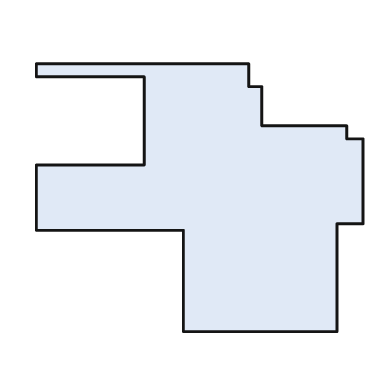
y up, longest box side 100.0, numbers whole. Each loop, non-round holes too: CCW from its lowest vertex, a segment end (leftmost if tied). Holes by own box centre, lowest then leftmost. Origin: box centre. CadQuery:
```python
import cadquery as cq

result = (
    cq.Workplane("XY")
    .moveTo(-5.0, -41.0)
    .lineTo(42.0, -41.0)
    .lineTo(42.0, -8.0)
    .lineTo(50.0, -8.0)
    .lineTo(50.0, 18.0)
    .lineTo(45.0, 18.0)
    .lineTo(45.0, 22.0)
    .lineTo(19.0, 22.0)
    .lineTo(19.0, 34.0)
    .lineTo(15.0, 34.0)
    .lineTo(15.0, 41.0)
    .lineTo(-50.0, 41.0)
    .lineTo(-50.0, 37.0)
    .lineTo(-17.0, 37.0)
    .lineTo(-17.0, 10.0)
    .lineTo(-50.0, 10.0)
    .lineTo(-50.0, -10.0)
    .lineTo(-5.0, -10.0)
    .close()
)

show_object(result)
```